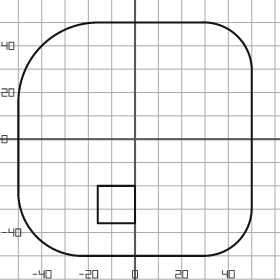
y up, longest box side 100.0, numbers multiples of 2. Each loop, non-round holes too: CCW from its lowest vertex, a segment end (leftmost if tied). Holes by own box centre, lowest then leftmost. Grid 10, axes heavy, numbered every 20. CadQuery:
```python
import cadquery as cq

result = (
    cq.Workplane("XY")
    .moveTo(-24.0, -50.0)
    .lineTo(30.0, -50.0)
    .threePointArc((44.0, -44.0), (50.0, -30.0))
    .lineTo(50.0, 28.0)
    .threePointArc((44.0, 44.0), (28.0, 50.0))
    .lineTo(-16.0, 50.0)
    .threePointArc((-40.0, 40.0), (-50.0, 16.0))
    .lineTo(-50.0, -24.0)
    .threePointArc((-42.0, -42.0), (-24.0, -50.0))
    .close()
    .moveTo(-16.0, -36.0)
    .lineTo(0.0, -36.0)
    .lineTo(0.0, -20.0)
    .lineTo(-16.0, -20.0)
    .close()
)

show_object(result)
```